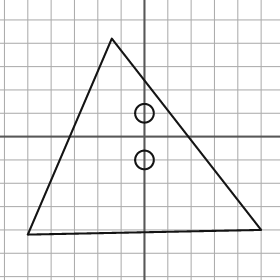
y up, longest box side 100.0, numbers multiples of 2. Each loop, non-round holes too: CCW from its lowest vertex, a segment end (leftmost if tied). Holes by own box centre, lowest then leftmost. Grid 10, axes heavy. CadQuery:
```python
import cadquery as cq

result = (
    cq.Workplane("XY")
    .moveTo(-50.0, -42.0)
    .lineTo(50.0, -40.0)
    .lineTo(-14.0, 42.0)
    .close()
    .moveTo(0.0, -10.0)
    .circle(4.0)
    .moveTo(0.0, 10.0)
    .circle(4.0)
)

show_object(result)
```